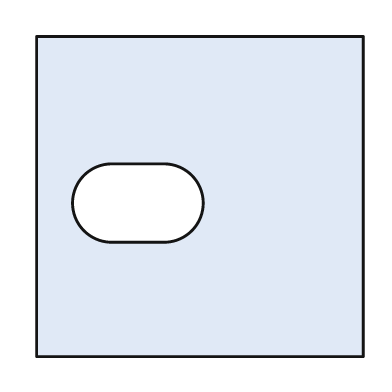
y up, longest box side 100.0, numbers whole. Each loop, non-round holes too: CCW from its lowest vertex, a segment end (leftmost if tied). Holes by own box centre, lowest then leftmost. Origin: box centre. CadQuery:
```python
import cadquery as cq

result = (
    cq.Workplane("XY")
    .moveTo(-50.0, -49.0)
    .lineTo(50.0, -49.0)
    .lineTo(50.0, 49.0)
    .lineTo(-50.0, 49.0)
    .close()
    .moveTo(-27.0, -14.0)
    .lineTo(-11.0, -14.0)
    .threePointArc((1.0, -2.0), (-11.0, 10.0))
    .lineTo(-27.0, 10.0)
    .threePointArc((-39.0, -2.0), (-27.0, -14.0))
    .close()
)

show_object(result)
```